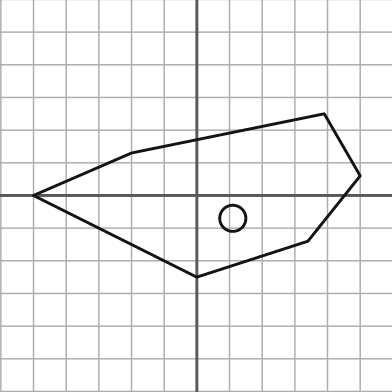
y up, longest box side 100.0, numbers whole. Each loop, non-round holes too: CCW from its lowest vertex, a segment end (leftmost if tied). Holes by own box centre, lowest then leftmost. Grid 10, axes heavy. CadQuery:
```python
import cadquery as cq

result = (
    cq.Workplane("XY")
    .moveTo(0.0, -25.0)
    .lineTo(34.0, -14.0)
    .lineTo(50.0, 6.0)
    .lineTo(39.0, 25.0)
    .lineTo(-20.0, 13.0)
    .lineTo(-50.0, 0.0)
    .close()
    .moveTo(11.0, -7.0)
    .circle(4.0)
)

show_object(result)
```